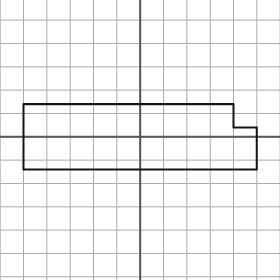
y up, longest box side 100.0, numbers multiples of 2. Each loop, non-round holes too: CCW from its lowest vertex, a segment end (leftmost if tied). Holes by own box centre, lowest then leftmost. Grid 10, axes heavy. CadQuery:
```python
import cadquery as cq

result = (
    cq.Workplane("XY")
    .moveTo(-50.0, -14.0)
    .lineTo(50.0, -14.0)
    .lineTo(50.0, 4.0)
    .lineTo(40.0, 4.0)
    .lineTo(40.0, 14.0)
    .lineTo(-50.0, 14.0)
    .close()
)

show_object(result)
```